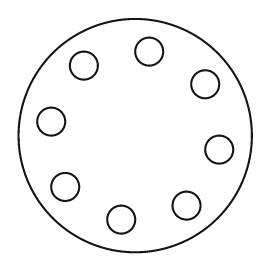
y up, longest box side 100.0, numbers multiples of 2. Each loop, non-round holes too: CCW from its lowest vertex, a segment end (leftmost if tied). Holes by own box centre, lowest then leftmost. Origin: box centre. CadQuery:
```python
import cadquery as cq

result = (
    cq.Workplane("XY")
    .moveTo(0.0, 0.0)
    .circle(50.0)
    .moveTo(-6.0, -36.0)
    .circle(6.0)
    .moveTo(22.0, -30.0)
    .circle(6.0)
    .moveTo(-30.0, -22.0)
    .circle(6.0)
    .moveTo(36.0, -6.0)
    .circle(6.0)
    .moveTo(-36.0, 6.0)
    .circle(6.0)
    .moveTo(30.0, 22.0)
    .circle(6.0)
    .moveTo(-22.0, 30.0)
    .circle(6.0)
    .moveTo(6.0, 36.0)
    .circle(6.0)
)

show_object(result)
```